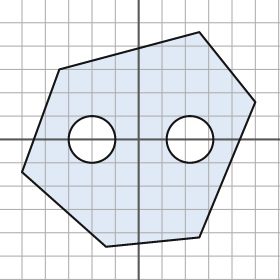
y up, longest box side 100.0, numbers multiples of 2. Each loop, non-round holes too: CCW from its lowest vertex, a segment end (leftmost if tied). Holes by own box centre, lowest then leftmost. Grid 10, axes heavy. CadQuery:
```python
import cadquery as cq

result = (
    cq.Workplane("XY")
    .moveTo(-14.0, -46.0)
    .lineTo(26.0, -42.0)
    .lineTo(50.0, 16.0)
    .lineTo(26.0, 46.0)
    .lineTo(-34.0, 30.0)
    .lineTo(-50.0, -14.0)
    .close()
    .moveTo(-20.0, 0.0)
    .circle(10.0)
    .moveTo(22.0, 0.0)
    .circle(10.0)
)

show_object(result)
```